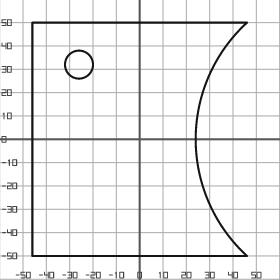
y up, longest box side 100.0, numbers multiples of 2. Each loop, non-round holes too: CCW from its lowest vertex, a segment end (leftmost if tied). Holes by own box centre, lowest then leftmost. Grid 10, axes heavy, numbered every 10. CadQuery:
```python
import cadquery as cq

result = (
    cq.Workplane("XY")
    .moveTo(-46.0, -50.0)
    .lineTo(46.0, -50.0)
    .threePointArc((24.0, 0.0), (46.0, 50.0))
    .lineTo(-46.0, 50.0)
    .close()
    .moveTo(-26.0, 32.0)
    .circle(6.0)
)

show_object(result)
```